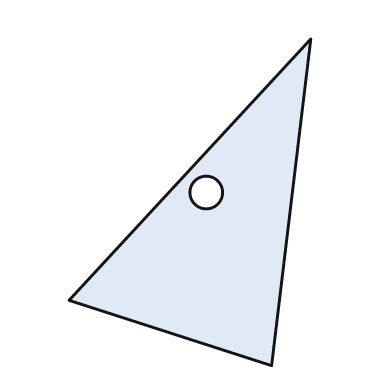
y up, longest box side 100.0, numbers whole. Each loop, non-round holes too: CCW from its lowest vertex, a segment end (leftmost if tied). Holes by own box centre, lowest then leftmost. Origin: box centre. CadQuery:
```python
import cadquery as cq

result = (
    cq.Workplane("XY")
    .moveTo(25.0, -50.0)
    .lineTo(37.0, 50.0)
    .lineTo(-37.0, -30.0)
    .close()
    .moveTo(5.0, 3.0)
    .circle(5.0)
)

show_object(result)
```